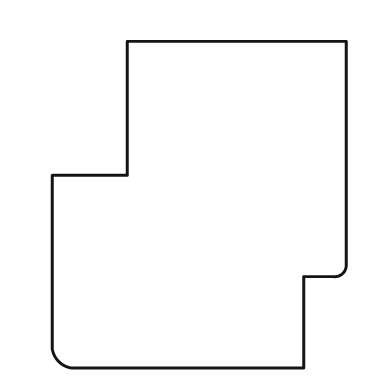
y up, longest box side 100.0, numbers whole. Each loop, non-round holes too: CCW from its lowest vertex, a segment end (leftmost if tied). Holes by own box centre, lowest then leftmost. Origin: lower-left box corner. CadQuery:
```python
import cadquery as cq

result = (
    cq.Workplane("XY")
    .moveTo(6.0, 0.0)
    .lineTo(77.0, 0.0)
    .lineTo(77.0, 28.0)
    .lineTo(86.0, 28.0)
    .threePointArc((89.0, 29.0), (90.0, 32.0))
    .lineTo(90.0, 100.0)
    .lineTo(23.0, 100.0)
    .lineTo(23.0, 59.0)
    .lineTo(0.0, 59.0)
    .lineTo(0.0, 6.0)
    .threePointArc((2.0, 2.0), (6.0, 0.0))
    .close()
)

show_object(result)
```